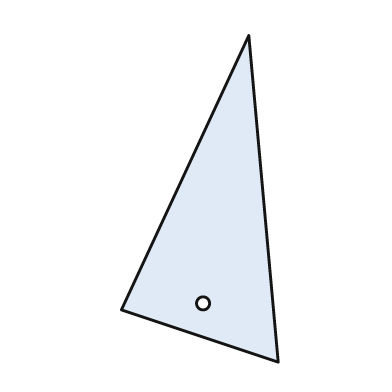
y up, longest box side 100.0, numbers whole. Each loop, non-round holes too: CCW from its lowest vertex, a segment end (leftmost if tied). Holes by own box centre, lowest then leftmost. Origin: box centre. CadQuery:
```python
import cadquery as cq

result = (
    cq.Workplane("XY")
    .moveTo(24.0, -50.0)
    .lineTo(15.0, 50.0)
    .lineTo(-24.0, -34.0)
    .close()
    .moveTo(1.0, -32.0)
    .circle(2.0)
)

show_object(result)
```